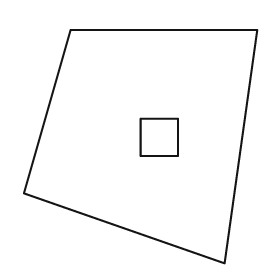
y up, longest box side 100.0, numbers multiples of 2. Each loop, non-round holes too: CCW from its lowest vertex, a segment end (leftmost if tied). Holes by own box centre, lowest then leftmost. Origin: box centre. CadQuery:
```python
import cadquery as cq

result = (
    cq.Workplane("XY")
    .moveTo(36.0, -50.0)
    .lineTo(50.0, 50.0)
    .lineTo(-30.0, 50.0)
    .lineTo(-50.0, -20.0)
    .close()
    .moveTo(0.0, -4.0)
    .lineTo(16.0, -4.0)
    .lineTo(16.0, 12.0)
    .lineTo(0.0, 12.0)
    .close()
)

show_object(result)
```